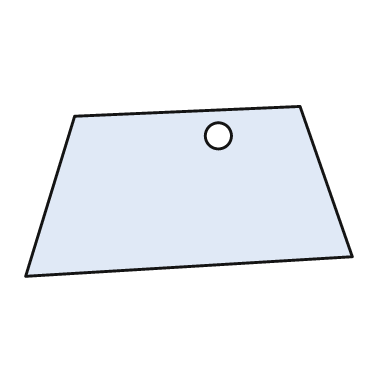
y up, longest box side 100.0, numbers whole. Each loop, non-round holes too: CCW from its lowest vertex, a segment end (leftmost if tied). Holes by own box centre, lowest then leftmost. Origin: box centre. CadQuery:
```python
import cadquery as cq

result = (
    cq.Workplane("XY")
    .moveTo(-50.0, -26.0)
    .lineTo(50.0, -20.0)
    .lineTo(34.0, 26.0)
    .lineTo(-35.0, 23.0)
    .close()
    .moveTo(9.0, 17.0)
    .circle(4.0)
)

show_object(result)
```